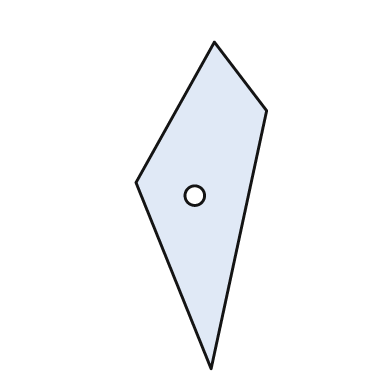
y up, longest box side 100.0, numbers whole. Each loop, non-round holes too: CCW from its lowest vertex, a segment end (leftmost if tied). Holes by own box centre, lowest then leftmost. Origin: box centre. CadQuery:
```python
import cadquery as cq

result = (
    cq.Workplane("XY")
    .moveTo(3.0, -50.0)
    .lineTo(20.0, 29.0)
    .lineTo(4.0, 50.0)
    .lineTo(-20.0, 7.0)
    .close()
    .moveTo(-2.0, 3.0)
    .circle(3.0)
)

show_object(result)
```